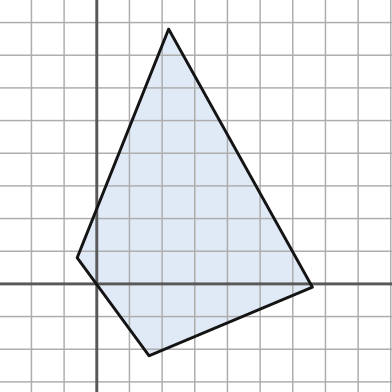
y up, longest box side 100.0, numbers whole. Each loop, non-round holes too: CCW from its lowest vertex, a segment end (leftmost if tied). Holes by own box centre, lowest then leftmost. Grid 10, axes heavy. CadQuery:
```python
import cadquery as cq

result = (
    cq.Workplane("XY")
    .moveTo(16.0, -22.0)
    .lineTo(66.0, -1.0)
    .lineTo(22.0, 78.0)
    .lineTo(-6.0, 8.0)
    .close()
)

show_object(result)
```